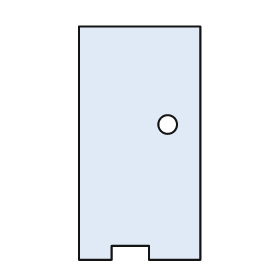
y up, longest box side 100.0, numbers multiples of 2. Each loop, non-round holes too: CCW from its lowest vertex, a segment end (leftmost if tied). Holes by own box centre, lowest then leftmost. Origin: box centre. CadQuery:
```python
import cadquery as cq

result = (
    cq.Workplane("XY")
    .moveTo(-26.0, -50.0)
    .lineTo(-12.0, -50.0)
    .lineTo(-12.0, -44.0)
    .lineTo(4.0, -44.0)
    .lineTo(4.0, -50.0)
    .lineTo(26.0, -50.0)
    .lineTo(26.0, 50.0)
    .lineTo(-26.0, 50.0)
    .close()
    .moveTo(12.0, 8.0)
    .circle(4.0)
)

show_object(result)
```